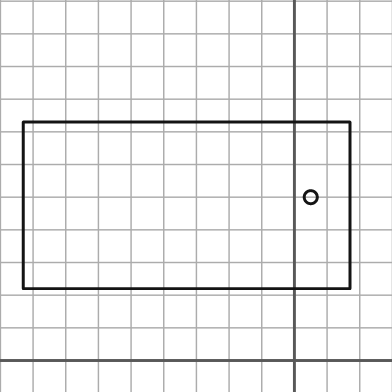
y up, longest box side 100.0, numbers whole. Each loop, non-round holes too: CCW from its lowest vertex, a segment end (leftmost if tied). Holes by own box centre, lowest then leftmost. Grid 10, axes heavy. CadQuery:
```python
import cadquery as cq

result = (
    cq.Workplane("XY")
    .moveTo(-83.0, 22.0)
    .lineTo(17.0, 22.0)
    .lineTo(17.0, 73.0)
    .lineTo(-83.0, 73.0)
    .close()
    .moveTo(5.0, 50.0)
    .circle(2.0)
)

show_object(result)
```